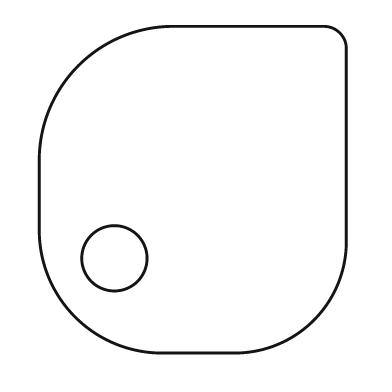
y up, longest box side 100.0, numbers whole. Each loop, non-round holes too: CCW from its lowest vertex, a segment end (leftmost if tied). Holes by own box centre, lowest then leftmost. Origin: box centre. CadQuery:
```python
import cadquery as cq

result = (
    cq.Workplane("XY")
    .moveTo(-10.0, -50.0)
    .lineTo(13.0, -50.0)
    .threePointArc((37.0, -40.0), (47.0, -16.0))
    .lineTo(47.0, 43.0)
    .threePointArc((45.0, 48.0), (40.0, 50.0))
    .lineTo(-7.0, 50.0)
    .threePointArc((-35.0, 38.0), (-47.0, 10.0))
    .lineTo(-47.0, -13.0)
    .threePointArc((-36.0, -39.0), (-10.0, -50.0))
    .close()
    .moveTo(-24.0, -21.0)
    .circle(10.0)
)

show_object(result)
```